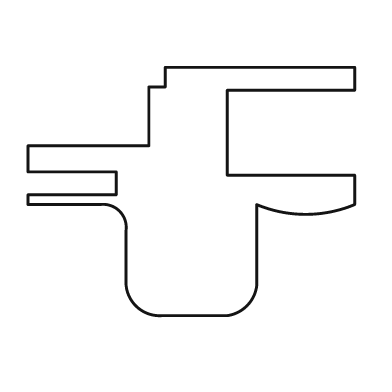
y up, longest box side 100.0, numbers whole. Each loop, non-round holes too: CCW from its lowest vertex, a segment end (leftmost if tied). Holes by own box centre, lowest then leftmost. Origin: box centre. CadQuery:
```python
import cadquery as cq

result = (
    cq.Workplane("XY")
    .moveTo(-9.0, -38.0)
    .lineTo(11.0, -38.0)
    .threePointArc((17.0, -35.0), (20.0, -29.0))
    .lineTo(20.0, -4.0)
    .threePointArc((35.0, -7.0), (50.0, -4.0))
    .lineTo(50.0, 5.0)
    .lineTo(11.0, 5.0)
    .lineTo(11.0, 31.0)
    .lineTo(50.0, 31.0)
    .lineTo(50.0, 38.0)
    .lineTo(-8.0, 38.0)
    .lineTo(-8.0, 32.0)
    .lineTo(-13.0, 32.0)
    .lineTo(-13.0, 14.0)
    .lineTo(-50.0, 14.0)
    .lineTo(-50.0, 6.0)
    .lineTo(-23.0, 6.0)
    .lineTo(-23.0, -1.0)
    .lineTo(-50.0, -1.0)
    .lineTo(-50.0, -4.0)
    .lineTo(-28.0, -4.0)
    .threePointArc((-22.0, -6.0), (-20.0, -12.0))
    .lineTo(-20.0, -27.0)
    .threePointArc((-17.0, -35.0), (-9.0, -38.0))
    .close()
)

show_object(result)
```